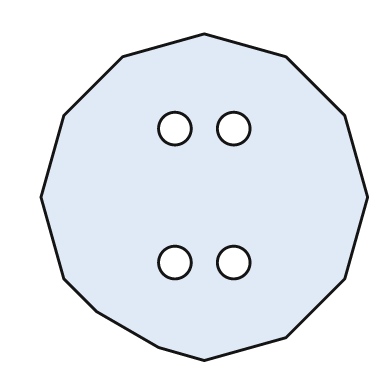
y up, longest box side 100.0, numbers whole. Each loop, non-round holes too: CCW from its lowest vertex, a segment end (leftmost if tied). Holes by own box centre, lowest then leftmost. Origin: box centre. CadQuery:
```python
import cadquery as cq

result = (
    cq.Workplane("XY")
    .moveTo(0.0, -50.0)
    .lineTo(25.0, -43.0)
    .lineTo(43.0, -25.0)
    .lineTo(50.0, 0.0)
    .lineTo(43.0, 25.0)
    .lineTo(25.0, 43.0)
    .lineTo(0.0, 50.0)
    .lineTo(-25.0, 43.0)
    .lineTo(-43.0, 25.0)
    .lineTo(-50.0, 0.0)
    .lineTo(-43.0, -25.0)
    .lineTo(-33.0, -35.0)
    .lineTo(-14.0, -46.0)
    .close()
    .moveTo(-9.0, -20.0)
    .circle(5.0)
    .moveTo(9.0, -20.0)
    .circle(5.0)
    .moveTo(-9.0, 21.0)
    .circle(5.0)
    .moveTo(9.0, 21.0)
    .circle(5.0)
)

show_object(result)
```